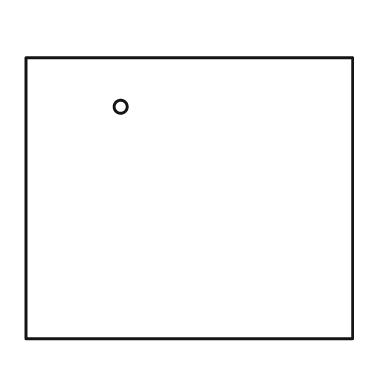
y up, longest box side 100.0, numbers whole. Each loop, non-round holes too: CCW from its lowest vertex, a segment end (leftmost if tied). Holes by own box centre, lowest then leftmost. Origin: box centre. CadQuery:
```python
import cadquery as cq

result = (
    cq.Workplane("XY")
    .moveTo(-50.0, -43.0)
    .lineTo(50.0, -43.0)
    .lineTo(50.0, 43.0)
    .lineTo(-50.0, 43.0)
    .close()
    .moveTo(-21.0, 28.0)
    .circle(2.0)
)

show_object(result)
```